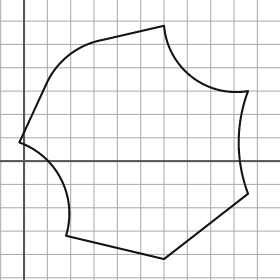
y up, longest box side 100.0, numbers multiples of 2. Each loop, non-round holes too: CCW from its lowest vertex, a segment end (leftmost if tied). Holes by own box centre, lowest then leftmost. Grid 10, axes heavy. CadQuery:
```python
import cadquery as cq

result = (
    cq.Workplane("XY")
    .moveTo(60.0, -42.0)
    .lineTo(96.0, -14.0)
    .threePointArc((92.0, 8.0), (96.0, 30.0))
    .threePointArc((72.0, 36.0), (60.0, 58.0))
    .lineTo(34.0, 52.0)
    .threePointArc((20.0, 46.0), (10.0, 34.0))
    .lineTo(-2.0, 8.0)
    .threePointArc((16.0, -8.0), (18.0, -32.0))
    .close()
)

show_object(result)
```